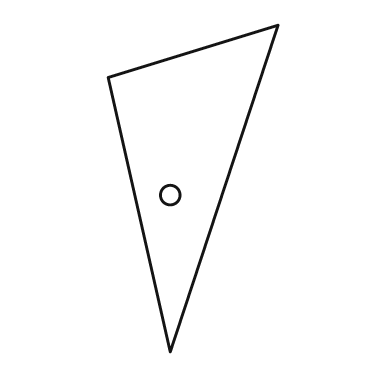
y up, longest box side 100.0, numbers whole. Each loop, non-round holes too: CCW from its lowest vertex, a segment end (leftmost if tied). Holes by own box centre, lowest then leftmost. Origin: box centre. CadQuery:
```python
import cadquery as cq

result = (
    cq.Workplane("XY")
    .moveTo(-7.0, -50.0)
    .lineTo(26.0, 50.0)
    .lineTo(-26.0, 34.0)
    .close()
    .moveTo(-7.0, -2.0)
    .circle(3.0)
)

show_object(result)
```